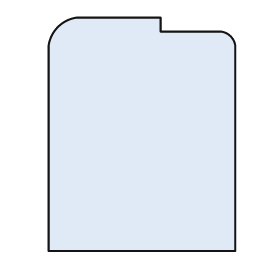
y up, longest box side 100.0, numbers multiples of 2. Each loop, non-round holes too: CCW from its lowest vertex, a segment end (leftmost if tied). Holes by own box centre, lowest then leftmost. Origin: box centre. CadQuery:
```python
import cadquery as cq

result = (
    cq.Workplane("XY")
    .moveTo(-40.0, -50.0)
    .lineTo(40.0, -50.0)
    .lineTo(40.0, 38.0)
    .threePointArc((38.0, 42.0), (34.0, 44.0))
    .lineTo(8.0, 44.0)
    .lineTo(8.0, 50.0)
    .lineTo(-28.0, 50.0)
    .threePointArc((-36.0, 46.0), (-40.0, 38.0))
    .close()
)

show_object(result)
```